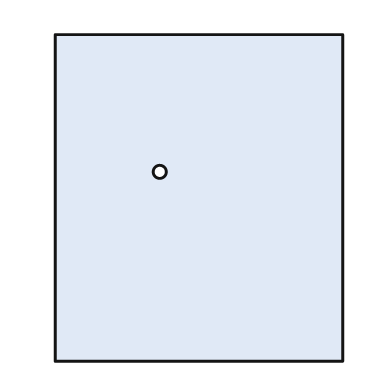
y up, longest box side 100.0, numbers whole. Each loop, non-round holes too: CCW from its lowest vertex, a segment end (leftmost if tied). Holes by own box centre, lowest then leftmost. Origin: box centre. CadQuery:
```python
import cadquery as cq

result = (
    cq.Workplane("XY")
    .moveTo(-44.0, -50.0)
    .lineTo(44.0, -50.0)
    .lineTo(44.0, 50.0)
    .lineTo(-44.0, 50.0)
    .close()
    .moveTo(-12.0, 8.0)
    .circle(2.0)
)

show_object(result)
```